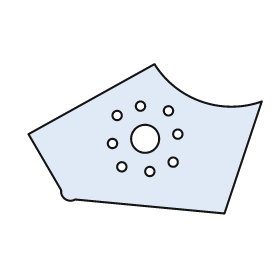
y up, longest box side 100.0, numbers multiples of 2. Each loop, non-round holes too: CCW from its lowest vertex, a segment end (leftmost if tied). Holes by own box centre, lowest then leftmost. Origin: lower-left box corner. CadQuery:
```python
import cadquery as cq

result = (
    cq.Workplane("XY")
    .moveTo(84.0, 0.0)
    .lineTo(100.0, 48.0)
    .threePointArc((74.0, 48.0), (54.0, 64.0))
    .lineTo(0.0, 34.0)
    .lineTo(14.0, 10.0)
    .threePointArc((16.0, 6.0), (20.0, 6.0))
    .close()
    .moveTo(52.0, 18.0)
    .circle(2.0)
    .moveTo(40.0, 20.0)
    .circle(2.0)
    .moveTo(62.0, 22.0)
    .circle(2.0)
    .moveTo(36.0, 30.0)
    .circle(2.0)
    .moveTo(50.0, 32.0)
    .circle(6.0)
    .moveTo(64.0, 34.0)
    .circle(2.0)
    .moveTo(38.0, 42.0)
    .circle(2.0)
    .moveTo(60.0, 44.0)
    .circle(2.0)
    .moveTo(48.0, 46.0)
    .circle(2.0)
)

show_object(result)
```